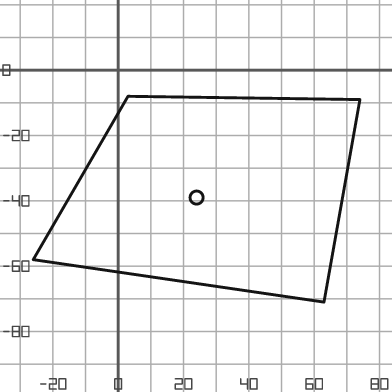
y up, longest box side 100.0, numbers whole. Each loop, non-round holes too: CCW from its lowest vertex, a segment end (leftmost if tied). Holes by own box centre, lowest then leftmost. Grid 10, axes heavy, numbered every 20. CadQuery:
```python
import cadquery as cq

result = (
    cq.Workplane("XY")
    .moveTo(63.0, -71.0)
    .lineTo(74.0, -9.0)
    .lineTo(3.0, -8.0)
    .lineTo(-26.0, -58.0)
    .close()
    .moveTo(24.0, -39.0)
    .circle(2.0)
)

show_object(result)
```